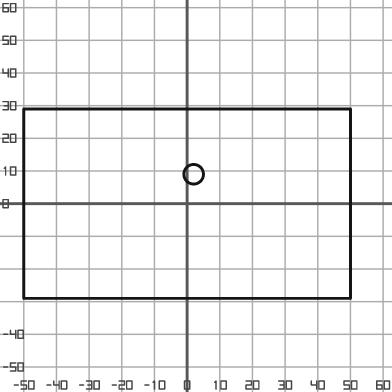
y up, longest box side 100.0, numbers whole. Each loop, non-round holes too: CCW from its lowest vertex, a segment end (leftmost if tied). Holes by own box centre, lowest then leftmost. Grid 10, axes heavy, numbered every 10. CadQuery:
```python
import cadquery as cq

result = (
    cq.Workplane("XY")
    .moveTo(-50.0, -29.0)
    .lineTo(50.0, -29.0)
    .lineTo(50.0, 29.0)
    .lineTo(-50.0, 29.0)
    .close()
    .moveTo(2.0, 9.0)
    .circle(3.0)
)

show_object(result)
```